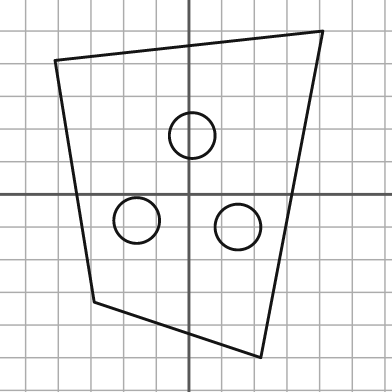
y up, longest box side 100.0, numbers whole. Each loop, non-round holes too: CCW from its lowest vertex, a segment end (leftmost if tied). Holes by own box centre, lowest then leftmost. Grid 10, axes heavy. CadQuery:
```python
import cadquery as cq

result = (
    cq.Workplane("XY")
    .moveTo(22.0, -50.0)
    .lineTo(41.0, 50.0)
    .lineTo(-41.0, 41.0)
    .lineTo(-29.0, -33.0)
    .close()
    .moveTo(15.0, -10.0)
    .circle(7.0)
    .moveTo(-16.0, -8.0)
    .circle(7.0)
    .moveTo(1.0, 18.0)
    .circle(7.0)
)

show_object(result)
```